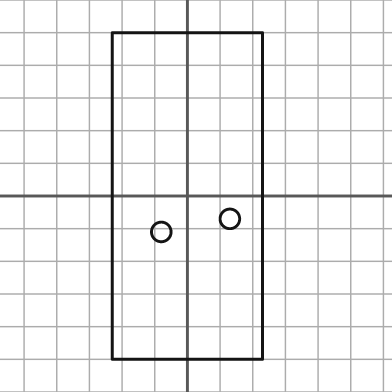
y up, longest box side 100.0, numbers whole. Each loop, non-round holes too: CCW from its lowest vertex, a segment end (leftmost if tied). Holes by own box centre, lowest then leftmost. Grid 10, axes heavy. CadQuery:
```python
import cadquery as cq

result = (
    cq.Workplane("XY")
    .moveTo(-23.0, -50.0)
    .lineTo(23.0, -50.0)
    .lineTo(23.0, 50.0)
    .lineTo(-23.0, 50.0)
    .close()
    .moveTo(-8.0, -11.0)
    .circle(3.0)
    .moveTo(13.0, -7.0)
    .circle(3.0)
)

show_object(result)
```